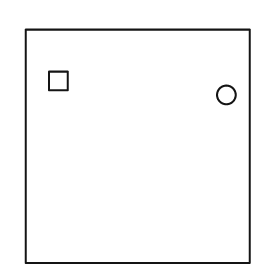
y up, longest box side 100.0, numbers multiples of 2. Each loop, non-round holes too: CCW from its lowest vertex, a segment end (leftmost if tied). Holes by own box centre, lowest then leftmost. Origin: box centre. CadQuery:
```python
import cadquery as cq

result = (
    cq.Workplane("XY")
    .moveTo(-48.0, -50.0)
    .lineTo(48.0, -50.0)
    .lineTo(48.0, 50.0)
    .lineTo(-48.0, 50.0)
    .close()
    .moveTo(38.0, 22.0)
    .circle(4.0)
    .moveTo(-38.0, 24.0)
    .lineTo(-30.0, 24.0)
    .lineTo(-30.0, 32.0)
    .lineTo(-38.0, 32.0)
    .close()
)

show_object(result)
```